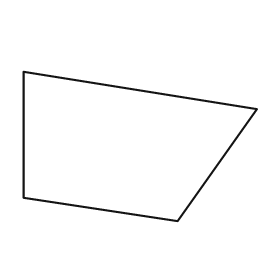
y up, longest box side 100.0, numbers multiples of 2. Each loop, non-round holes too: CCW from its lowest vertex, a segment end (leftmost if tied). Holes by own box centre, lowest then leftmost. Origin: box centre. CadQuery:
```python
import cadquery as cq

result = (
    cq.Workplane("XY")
    .moveTo(16.0, -32.0)
    .lineTo(50.0, 16.0)
    .lineTo(-50.0, 32.0)
    .lineTo(-50.0, -22.0)
    .close()
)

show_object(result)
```